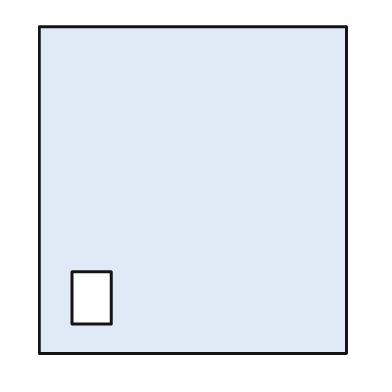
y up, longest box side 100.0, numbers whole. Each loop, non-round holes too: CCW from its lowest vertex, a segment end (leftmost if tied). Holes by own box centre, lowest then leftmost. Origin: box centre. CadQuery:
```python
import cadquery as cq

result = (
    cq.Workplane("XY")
    .moveTo(-47.0, -50.0)
    .lineTo(47.0, -50.0)
    .lineTo(47.0, 50.0)
    .lineTo(-47.0, 50.0)
    .close()
    .moveTo(-37.0, -41.0)
    .lineTo(-25.0, -41.0)
    .lineTo(-25.0, -25.0)
    .lineTo(-37.0, -25.0)
    .close()
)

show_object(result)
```